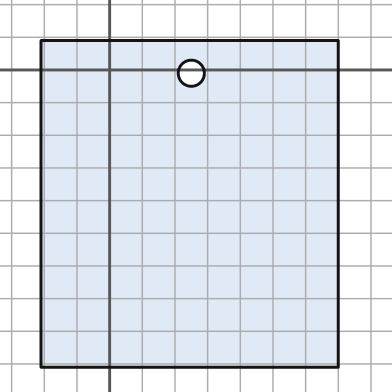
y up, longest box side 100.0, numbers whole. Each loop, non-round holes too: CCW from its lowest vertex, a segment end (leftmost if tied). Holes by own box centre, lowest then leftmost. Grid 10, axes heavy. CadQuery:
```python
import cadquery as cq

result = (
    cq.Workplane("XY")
    .moveTo(-21.0, -91.0)
    .lineTo(70.0, -91.0)
    .lineTo(70.0, 9.0)
    .lineTo(-21.0, 9.0)
    .close()
    .moveTo(25.0, -1.0)
    .circle(4.0)
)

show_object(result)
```